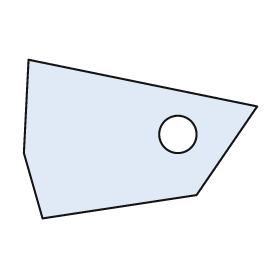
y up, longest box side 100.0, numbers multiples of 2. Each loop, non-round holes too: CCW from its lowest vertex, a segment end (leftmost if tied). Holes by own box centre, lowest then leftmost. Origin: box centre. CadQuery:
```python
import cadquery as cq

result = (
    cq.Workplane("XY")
    .moveTo(-42.0, -34.0)
    .lineTo(24.0, -24.0)
    .lineTo(50.0, 14.0)
    .lineTo(-48.0, 34.0)
    .lineTo(-50.0, -6.0)
    .close()
    .moveTo(16.0, 2.0)
    .circle(8.0)
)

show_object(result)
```